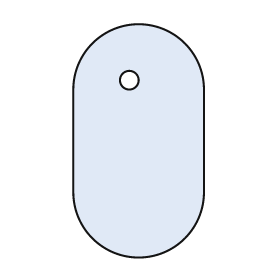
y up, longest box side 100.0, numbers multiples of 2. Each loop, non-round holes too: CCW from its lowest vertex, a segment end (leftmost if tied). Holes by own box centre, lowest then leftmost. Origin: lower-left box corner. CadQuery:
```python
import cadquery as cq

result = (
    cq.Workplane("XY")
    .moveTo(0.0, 28.0)
    .threePointArc((28.0, 0.0), (56.0, 28.0))
    .lineTo(56.0, 72.0)
    .threePointArc((28.0, 100.0), (0.0, 72.0))
    .close()
    .moveTo(24.0, 76.0)
    .circle(4.0)
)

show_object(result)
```